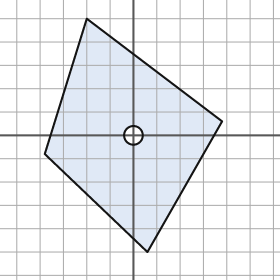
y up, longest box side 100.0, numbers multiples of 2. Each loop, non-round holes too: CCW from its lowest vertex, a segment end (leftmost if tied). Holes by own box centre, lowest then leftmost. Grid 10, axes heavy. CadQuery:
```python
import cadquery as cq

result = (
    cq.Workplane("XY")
    .moveTo(6.0, -50.0)
    .lineTo(38.0, 6.0)
    .lineTo(-20.0, 50.0)
    .lineTo(-38.0, -8.0)
    .close()
    .moveTo(0.0, 0.0)
    .circle(4.0)
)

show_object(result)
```